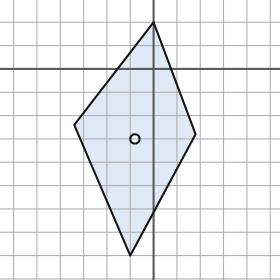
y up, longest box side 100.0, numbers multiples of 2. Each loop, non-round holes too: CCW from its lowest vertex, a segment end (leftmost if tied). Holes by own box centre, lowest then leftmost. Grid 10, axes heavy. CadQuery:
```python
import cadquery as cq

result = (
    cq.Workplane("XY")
    .moveTo(-10.0, -80.0)
    .lineTo(18.0, -28.0)
    .lineTo(0.0, 20.0)
    .lineTo(-34.0, -24.0)
    .close()
    .moveTo(-8.0, -30.0)
    .circle(2.0)
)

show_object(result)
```